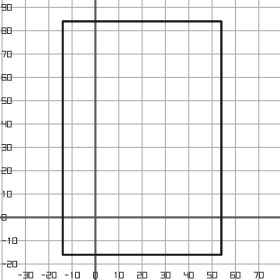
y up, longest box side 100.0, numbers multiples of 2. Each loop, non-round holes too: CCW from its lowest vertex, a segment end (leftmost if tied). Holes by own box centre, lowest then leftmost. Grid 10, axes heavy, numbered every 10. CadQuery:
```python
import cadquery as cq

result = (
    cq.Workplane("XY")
    .moveTo(-14.0, -16.0)
    .lineTo(54.0, -16.0)
    .lineTo(54.0, 84.0)
    .lineTo(-14.0, 84.0)
    .close()
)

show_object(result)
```